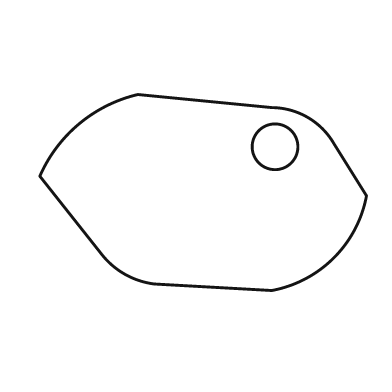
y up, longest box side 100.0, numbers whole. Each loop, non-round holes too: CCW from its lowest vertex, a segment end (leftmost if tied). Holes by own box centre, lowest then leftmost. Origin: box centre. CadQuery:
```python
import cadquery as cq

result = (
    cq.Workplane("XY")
    .moveTo(21.0, -30.0)
    .threePointArc((40.0, -20.0), (50.0, -1.0))
    .lineTo(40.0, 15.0)
    .threePointArc((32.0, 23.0), (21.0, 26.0))
    .lineTo(-20.0, 30.0)
    .threePointArc((-38.0, 21.0), (-50.0, 5.0))
    .lineTo(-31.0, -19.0)
    .threePointArc((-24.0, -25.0), (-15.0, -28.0))
    .close()
    .moveTo(22.0, 14.0)
    .circle(7.0)
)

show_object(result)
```